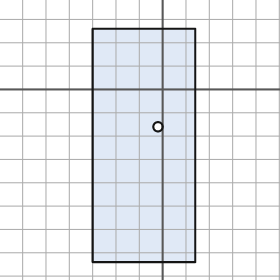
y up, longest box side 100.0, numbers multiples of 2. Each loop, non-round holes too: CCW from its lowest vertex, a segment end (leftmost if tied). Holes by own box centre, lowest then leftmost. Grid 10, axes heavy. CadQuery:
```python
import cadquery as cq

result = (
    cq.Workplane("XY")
    .moveTo(-30.0, -74.0)
    .lineTo(14.0, -74.0)
    .lineTo(14.0, 26.0)
    .lineTo(-30.0, 26.0)
    .close()
    .moveTo(-2.0, -16.0)
    .circle(2.0)
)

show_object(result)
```